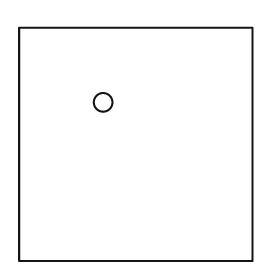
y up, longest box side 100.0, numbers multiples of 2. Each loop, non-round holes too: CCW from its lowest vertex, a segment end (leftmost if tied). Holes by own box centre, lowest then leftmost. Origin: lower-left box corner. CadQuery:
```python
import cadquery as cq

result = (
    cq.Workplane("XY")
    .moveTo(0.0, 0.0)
    .lineTo(100.0, 0.0)
    .lineTo(100.0, 100.0)
    .lineTo(0.0, 100.0)
    .close()
    .moveTo(36.0, 68.0)
    .circle(4.0)
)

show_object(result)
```